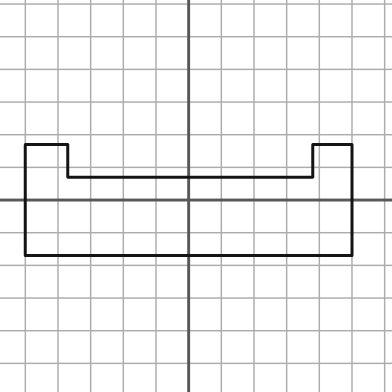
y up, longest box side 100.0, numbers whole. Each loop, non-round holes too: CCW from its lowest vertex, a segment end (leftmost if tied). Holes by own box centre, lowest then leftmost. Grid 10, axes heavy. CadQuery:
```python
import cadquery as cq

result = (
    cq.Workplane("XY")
    .moveTo(-50.0, -17.0)
    .lineTo(50.0, -17.0)
    .lineTo(50.0, 17.0)
    .lineTo(38.0, 17.0)
    .lineTo(38.0, 7.0)
    .lineTo(-37.0, 7.0)
    .lineTo(-37.0, 17.0)
    .lineTo(-50.0, 17.0)
    .close()
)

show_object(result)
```